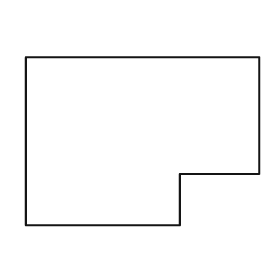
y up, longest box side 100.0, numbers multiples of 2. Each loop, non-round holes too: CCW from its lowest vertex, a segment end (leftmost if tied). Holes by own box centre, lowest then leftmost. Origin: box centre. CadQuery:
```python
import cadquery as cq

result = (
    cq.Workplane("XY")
    .moveTo(-50.0, -36.0)
    .lineTo(16.0, -36.0)
    .lineTo(16.0, -14.0)
    .lineTo(50.0, -14.0)
    .lineTo(50.0, 36.0)
    .lineTo(-50.0, 36.0)
    .close()
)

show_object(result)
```